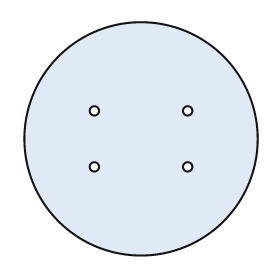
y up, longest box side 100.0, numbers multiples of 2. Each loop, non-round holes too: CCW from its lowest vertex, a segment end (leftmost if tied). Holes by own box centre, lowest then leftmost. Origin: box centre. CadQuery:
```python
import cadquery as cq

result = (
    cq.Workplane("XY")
    .moveTo(0.0, 0.0)
    .circle(50.0)
    .moveTo(-20.0, -12.0)
    .circle(2.0)
    .moveTo(20.0, -12.0)
    .circle(2.0)
    .moveTo(-20.0, 12.0)
    .circle(2.0)
    .moveTo(20.0, 12.0)
    .circle(2.0)
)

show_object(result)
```